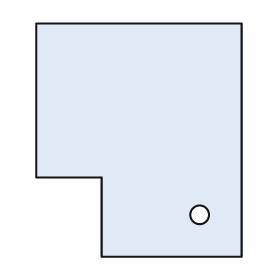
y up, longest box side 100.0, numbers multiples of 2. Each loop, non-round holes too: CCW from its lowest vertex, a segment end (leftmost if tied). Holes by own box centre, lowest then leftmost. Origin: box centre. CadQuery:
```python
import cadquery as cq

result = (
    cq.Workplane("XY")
    .moveTo(-16.0, -50.0)
    .lineTo(44.0, -50.0)
    .lineTo(44.0, 50.0)
    .lineTo(-44.0, 50.0)
    .lineTo(-44.0, -16.0)
    .lineTo(-16.0, -16.0)
    .close()
    .moveTo(26.0, -32.0)
    .circle(4.0)
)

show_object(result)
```